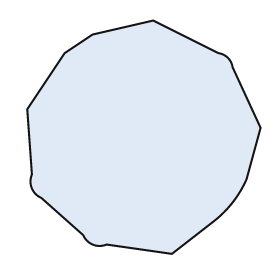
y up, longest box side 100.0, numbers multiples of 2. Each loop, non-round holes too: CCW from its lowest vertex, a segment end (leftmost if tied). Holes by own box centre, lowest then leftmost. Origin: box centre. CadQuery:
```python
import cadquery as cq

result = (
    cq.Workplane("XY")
    .moveTo(12.0, -50.0)
    .lineTo(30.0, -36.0)
    .threePointArc((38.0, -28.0), (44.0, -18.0))
    .lineTo(50.0, 4.0)
    .lineTo(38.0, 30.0)
    .threePointArc((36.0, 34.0), (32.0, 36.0))
    .lineTo(4.0, 50.0)
    .lineTo(-22.0, 44.0)
    .lineTo(-34.0, 36.0)
    .lineTo(-50.0, 12.0)
    .lineTo(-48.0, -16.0)
    .threePointArc((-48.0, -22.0), (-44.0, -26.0))
    .lineTo(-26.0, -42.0)
    .threePointArc((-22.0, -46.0), (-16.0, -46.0))
    .close()
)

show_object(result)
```